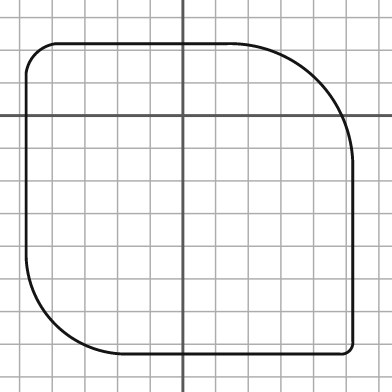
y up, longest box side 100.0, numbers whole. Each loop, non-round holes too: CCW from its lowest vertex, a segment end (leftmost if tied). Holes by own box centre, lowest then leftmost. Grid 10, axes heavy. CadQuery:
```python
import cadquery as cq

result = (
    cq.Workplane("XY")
    .moveTo(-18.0, -73.0)
    .lineTo(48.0, -73.0)
    .threePointArc((51.0, -72.0), (52.0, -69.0))
    .lineTo(52.0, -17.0)
    .threePointArc((41.0, 11.0), (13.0, 22.0))
    .lineTo(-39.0, 22.0)
    .threePointArc((-45.0, 19.0), (-48.0, 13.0))
    .lineTo(-48.0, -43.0)
    .threePointArc((-39.0, -64.0), (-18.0, -73.0))
    .close()
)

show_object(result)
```